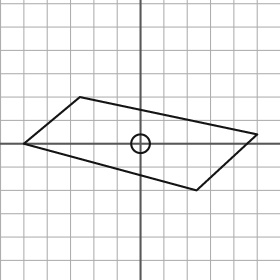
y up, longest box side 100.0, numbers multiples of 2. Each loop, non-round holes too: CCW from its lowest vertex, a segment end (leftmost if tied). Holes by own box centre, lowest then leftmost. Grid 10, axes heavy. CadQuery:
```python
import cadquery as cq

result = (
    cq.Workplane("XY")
    .moveTo(24.0, -20.0)
    .lineTo(50.0, 4.0)
    .lineTo(-26.0, 20.0)
    .lineTo(-50.0, 0.0)
    .close()
    .moveTo(0.0, 0.0)
    .circle(4.0)
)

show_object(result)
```